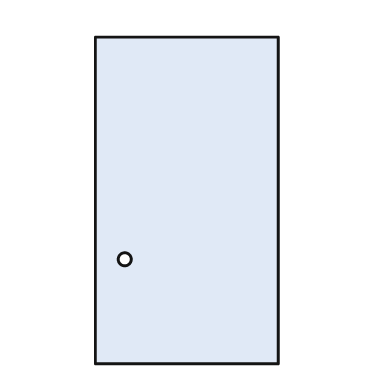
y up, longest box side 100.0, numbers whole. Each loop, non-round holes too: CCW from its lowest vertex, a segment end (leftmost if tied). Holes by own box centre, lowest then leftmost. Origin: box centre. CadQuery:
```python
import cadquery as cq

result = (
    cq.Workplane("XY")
    .moveTo(-28.0, -50.0)
    .lineTo(28.0, -50.0)
    .lineTo(28.0, 50.0)
    .lineTo(-28.0, 50.0)
    .close()
    .moveTo(-19.0, -18.0)
    .circle(2.0)
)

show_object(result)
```